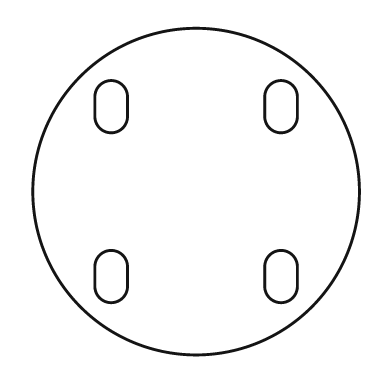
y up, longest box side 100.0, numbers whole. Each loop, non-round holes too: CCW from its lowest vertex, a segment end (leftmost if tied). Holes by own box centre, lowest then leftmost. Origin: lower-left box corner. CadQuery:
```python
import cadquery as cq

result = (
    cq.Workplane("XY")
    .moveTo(50.0, 50.0)
    .circle(50.0)
    .moveTo(19.0, 21.0)
    .threePointArc((24.0, 16.0), (29.0, 21.0))
    .lineTo(29.0, 27.0)
    .threePointArc((24.0, 32.0), (19.0, 27.0))
    .close()
    .moveTo(71.0, 21.0)
    .threePointArc((76.0, 16.0), (81.0, 21.0))
    .lineTo(81.0, 27.0)
    .threePointArc((76.0, 32.0), (71.0, 27.0))
    .close()
    .moveTo(19.0, 73.0)
    .threePointArc((24.0, 68.0), (29.0, 73.0))
    .lineTo(29.0, 79.0)
    .threePointArc((24.0, 84.0), (19.0, 79.0))
    .close()
    .moveTo(71.0, 73.0)
    .threePointArc((76.0, 68.0), (81.0, 73.0))
    .lineTo(81.0, 79.0)
    .threePointArc((76.0, 84.0), (71.0, 79.0))
    .close()
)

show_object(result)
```